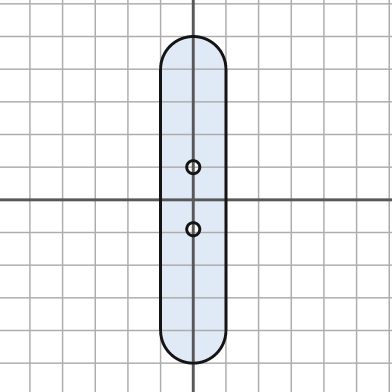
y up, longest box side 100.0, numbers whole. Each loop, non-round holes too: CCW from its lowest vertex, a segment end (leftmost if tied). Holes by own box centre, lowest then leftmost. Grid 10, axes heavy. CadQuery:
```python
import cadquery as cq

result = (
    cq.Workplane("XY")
    .moveTo(-10.0, -40.0)
    .threePointArc((0.0, -50.0), (10.0, -40.0))
    .lineTo(10.0, 40.0)
    .threePointArc((0.0, 50.0), (-10.0, 40.0))
    .close()
    .moveTo(0.0, -9.0)
    .circle(2.0)
    .moveTo(0.0, 10.0)
    .circle(2.0)
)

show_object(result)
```